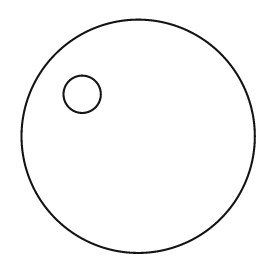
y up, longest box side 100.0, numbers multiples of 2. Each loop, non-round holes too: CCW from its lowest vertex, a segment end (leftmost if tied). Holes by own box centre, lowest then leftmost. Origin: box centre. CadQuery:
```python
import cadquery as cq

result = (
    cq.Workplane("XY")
    .moveTo(0.0, 0.0)
    .circle(50.0)
    .moveTo(-24.0, 18.0)
    .circle(8.0)
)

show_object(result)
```